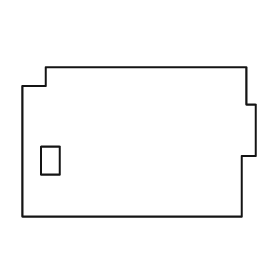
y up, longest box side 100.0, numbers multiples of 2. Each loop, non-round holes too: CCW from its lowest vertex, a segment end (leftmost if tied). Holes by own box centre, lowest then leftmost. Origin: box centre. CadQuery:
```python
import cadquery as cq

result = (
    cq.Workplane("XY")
    .moveTo(-50.0, -32.0)
    .lineTo(44.0, -32.0)
    .lineTo(44.0, -6.0)
    .lineTo(50.0, -6.0)
    .lineTo(50.0, 16.0)
    .lineTo(46.0, 16.0)
    .lineTo(46.0, 32.0)
    .lineTo(-40.0, 32.0)
    .lineTo(-40.0, 24.0)
    .lineTo(-50.0, 24.0)
    .close()
    .moveTo(-42.0, -14.0)
    .lineTo(-34.0, -14.0)
    .lineTo(-34.0, -2.0)
    .lineTo(-42.0, -2.0)
    .close()
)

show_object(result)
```